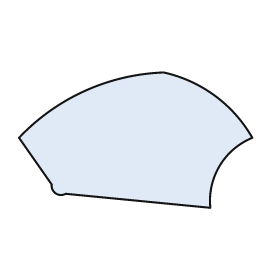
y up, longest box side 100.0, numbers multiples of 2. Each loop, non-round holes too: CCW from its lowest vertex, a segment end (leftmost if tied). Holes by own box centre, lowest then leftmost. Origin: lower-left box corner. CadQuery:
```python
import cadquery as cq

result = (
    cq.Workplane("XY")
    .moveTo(82.0, 0.0)
    .threePointArc((86.0, 18.0), (100.0, 30.0))
    .threePointArc((84.0, 48.0), (62.0, 58.0))
    .threePointArc((28.0, 50.0), (0.0, 30.0))
    .lineTo(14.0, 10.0)
    .threePointArc((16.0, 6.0), (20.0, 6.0))
    .close()
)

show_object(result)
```